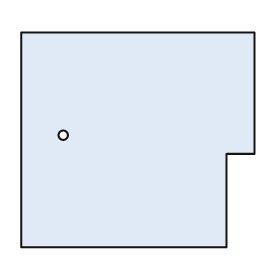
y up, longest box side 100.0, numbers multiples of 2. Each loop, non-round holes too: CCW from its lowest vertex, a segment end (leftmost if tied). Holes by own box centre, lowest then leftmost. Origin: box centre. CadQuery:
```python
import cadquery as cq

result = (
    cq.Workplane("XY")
    .moveTo(-50.0, -46.0)
    .lineTo(38.0, -46.0)
    .lineTo(38.0, -6.0)
    .lineTo(50.0, -6.0)
    .lineTo(50.0, 46.0)
    .lineTo(-50.0, 46.0)
    .close()
    .moveTo(-32.0, 2.0)
    .circle(2.0)
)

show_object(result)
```